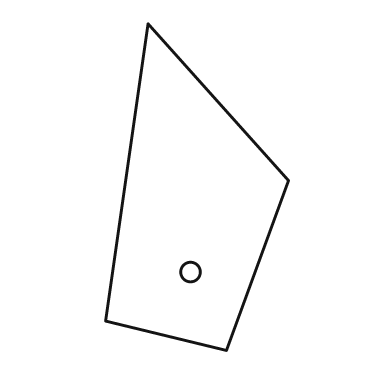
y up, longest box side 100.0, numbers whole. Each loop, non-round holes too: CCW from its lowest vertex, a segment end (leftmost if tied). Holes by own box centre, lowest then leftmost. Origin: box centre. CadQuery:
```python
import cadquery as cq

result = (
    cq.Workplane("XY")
    .moveTo(9.0, -50.0)
    .lineTo(28.0, 2.0)
    .lineTo(-15.0, 50.0)
    .lineTo(-28.0, -41.0)
    .close()
    .moveTo(-2.0, -26.0)
    .circle(3.0)
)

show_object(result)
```